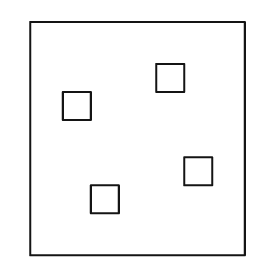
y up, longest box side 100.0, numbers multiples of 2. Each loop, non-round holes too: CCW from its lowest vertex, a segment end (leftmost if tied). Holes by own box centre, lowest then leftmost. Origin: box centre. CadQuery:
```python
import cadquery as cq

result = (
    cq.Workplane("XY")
    .moveTo(-46.0, -50.0)
    .lineTo(46.0, -50.0)
    .lineTo(46.0, 50.0)
    .lineTo(-46.0, 50.0)
    .close()
    .moveTo(-20.0, -32.0)
    .lineTo(-8.0, -32.0)
    .lineTo(-8.0, -20.0)
    .lineTo(-20.0, -20.0)
    .close()
    .moveTo(20.0, -20.0)
    .lineTo(32.0, -20.0)
    .lineTo(32.0, -8.0)
    .lineTo(20.0, -8.0)
    .close()
    .moveTo(-32.0, 8.0)
    .lineTo(-20.0, 8.0)
    .lineTo(-20.0, 20.0)
    .lineTo(-32.0, 20.0)
    .close()
    .moveTo(8.0, 20.0)
    .lineTo(20.0, 20.0)
    .lineTo(20.0, 32.0)
    .lineTo(8.0, 32.0)
    .close()
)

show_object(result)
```